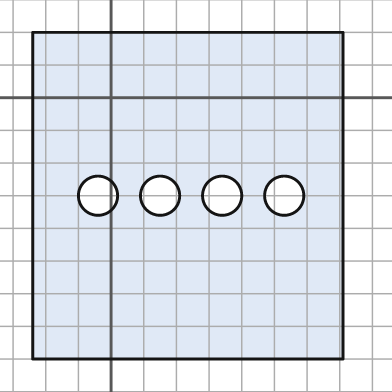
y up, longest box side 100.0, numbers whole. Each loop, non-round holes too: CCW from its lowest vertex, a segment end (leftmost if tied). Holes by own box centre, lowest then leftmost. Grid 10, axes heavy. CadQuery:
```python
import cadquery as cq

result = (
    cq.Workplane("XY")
    .moveTo(-24.0, -80.0)
    .lineTo(71.0, -80.0)
    .lineTo(71.0, 20.0)
    .lineTo(-24.0, 20.0)
    .close()
    .moveTo(-4.0, -30.0)
    .circle(6.0)
    .moveTo(15.0, -30.0)
    .circle(6.0)
    .moveTo(34.0, -30.0)
    .circle(6.0)
    .moveTo(53.0, -30.0)
    .circle(6.0)
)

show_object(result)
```